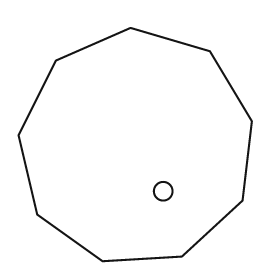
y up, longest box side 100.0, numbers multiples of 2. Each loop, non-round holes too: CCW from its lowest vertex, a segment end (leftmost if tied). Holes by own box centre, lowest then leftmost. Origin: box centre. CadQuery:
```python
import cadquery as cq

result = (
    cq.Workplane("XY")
    .moveTo(-14.0, -50.0)
    .lineTo(20.0, -48.0)
    .lineTo(46.0, -24.0)
    .lineTo(50.0, 10.0)
    .lineTo(32.0, 40.0)
    .lineTo(-2.0, 50.0)
    .lineTo(-34.0, 36.0)
    .lineTo(-50.0, 4.0)
    .lineTo(-42.0, -30.0)
    .close()
    .moveTo(12.0, -20.0)
    .circle(4.0)
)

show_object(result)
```